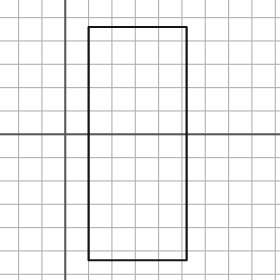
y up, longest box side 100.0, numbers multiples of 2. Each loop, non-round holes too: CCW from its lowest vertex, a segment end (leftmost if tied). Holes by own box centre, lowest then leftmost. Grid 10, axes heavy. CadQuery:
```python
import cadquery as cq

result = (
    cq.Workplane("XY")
    .moveTo(10.0, -54.0)
    .lineTo(52.0, -54.0)
    .lineTo(52.0, 46.0)
    .lineTo(10.0, 46.0)
    .close()
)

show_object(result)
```